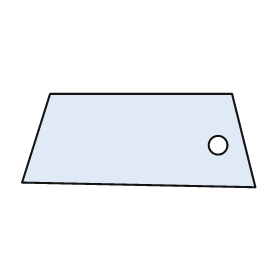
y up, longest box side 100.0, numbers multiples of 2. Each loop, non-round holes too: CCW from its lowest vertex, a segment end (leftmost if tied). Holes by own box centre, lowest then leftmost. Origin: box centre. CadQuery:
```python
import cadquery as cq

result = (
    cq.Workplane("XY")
    .moveTo(50.0, -20.0)
    .lineTo(40.0, 20.0)
    .lineTo(-38.0, 20.0)
    .lineTo(-50.0, -18.0)
    .close()
    .moveTo(34.0, -2.0)
    .circle(4.0)
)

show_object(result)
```